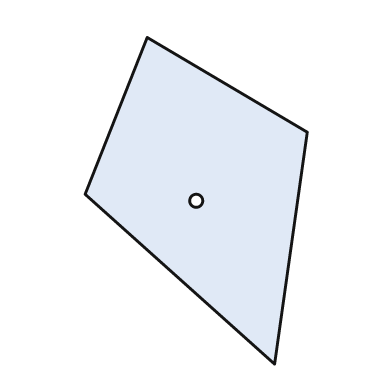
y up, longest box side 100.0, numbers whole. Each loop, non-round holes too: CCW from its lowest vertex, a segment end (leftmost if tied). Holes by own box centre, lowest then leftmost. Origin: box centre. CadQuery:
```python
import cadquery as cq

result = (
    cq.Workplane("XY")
    .moveTo(24.0, -50.0)
    .lineTo(34.0, 21.0)
    .lineTo(-15.0, 50.0)
    .lineTo(-34.0, 2.0)
    .close()
    .moveTo(0.0, 0.0)
    .circle(2.0)
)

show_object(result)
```